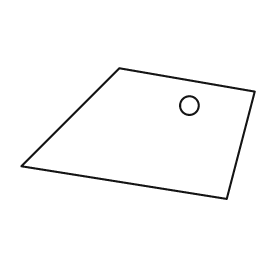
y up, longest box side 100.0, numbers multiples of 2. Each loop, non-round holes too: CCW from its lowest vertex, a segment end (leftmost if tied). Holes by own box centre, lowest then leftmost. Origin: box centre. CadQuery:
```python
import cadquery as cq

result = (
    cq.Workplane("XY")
    .moveTo(38.0, -28.0)
    .lineTo(50.0, 18.0)
    .lineTo(-8.0, 28.0)
    .lineTo(-50.0, -14.0)
    .close()
    .moveTo(22.0, 12.0)
    .circle(4.0)
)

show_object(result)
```